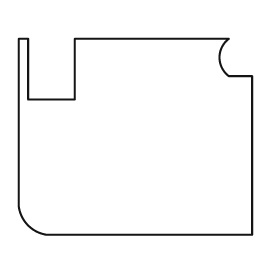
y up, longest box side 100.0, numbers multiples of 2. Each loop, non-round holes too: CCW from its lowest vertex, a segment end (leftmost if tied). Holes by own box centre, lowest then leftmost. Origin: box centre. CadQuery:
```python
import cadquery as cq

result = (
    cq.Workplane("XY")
    .moveTo(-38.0, -42.0)
    .lineTo(50.0, -42.0)
    .lineTo(50.0, 26.0)
    .lineTo(40.0, 26.0)
    .threePointArc((36.0, 34.0), (40.0, 42.0))
    .lineTo(-26.0, 42.0)
    .lineTo(-26.0, 16.0)
    .lineTo(-46.0, 16.0)
    .lineTo(-46.0, 42.0)
    .lineTo(-50.0, 42.0)
    .lineTo(-50.0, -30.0)
    .threePointArc((-46.0, -38.0), (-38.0, -42.0))
    .close()
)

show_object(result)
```